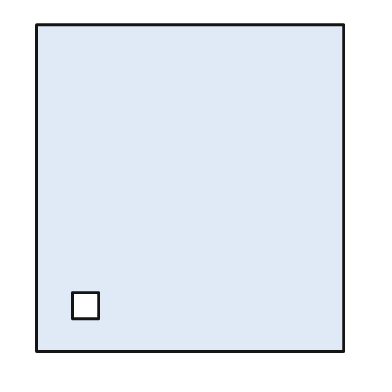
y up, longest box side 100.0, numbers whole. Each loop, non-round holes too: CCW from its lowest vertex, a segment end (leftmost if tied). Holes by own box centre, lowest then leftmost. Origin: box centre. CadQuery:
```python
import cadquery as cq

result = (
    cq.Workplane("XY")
    .moveTo(-47.0, -50.0)
    .lineTo(47.0, -50.0)
    .lineTo(47.0, 50.0)
    .lineTo(-47.0, 50.0)
    .close()
    .moveTo(-36.0, -40.0)
    .lineTo(-28.0, -40.0)
    .lineTo(-28.0, -32.0)
    .lineTo(-36.0, -32.0)
    .close()
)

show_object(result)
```